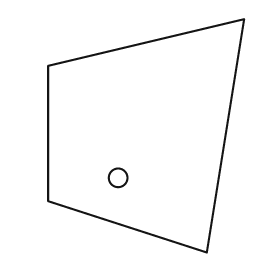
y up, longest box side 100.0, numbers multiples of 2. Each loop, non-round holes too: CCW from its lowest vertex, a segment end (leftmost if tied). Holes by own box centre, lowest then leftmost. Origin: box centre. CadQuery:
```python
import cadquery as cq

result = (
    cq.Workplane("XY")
    .moveTo(26.0, -50.0)
    .lineTo(42.0, 50.0)
    .lineTo(-42.0, 30.0)
    .lineTo(-42.0, -28.0)
    .close()
    .moveTo(-12.0, -18.0)
    .circle(4.0)
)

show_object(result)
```